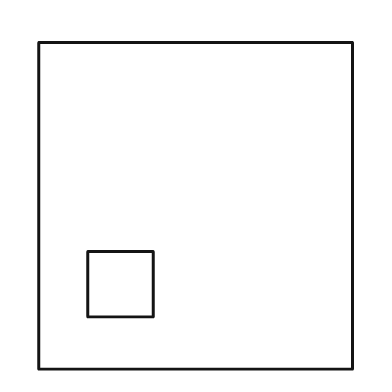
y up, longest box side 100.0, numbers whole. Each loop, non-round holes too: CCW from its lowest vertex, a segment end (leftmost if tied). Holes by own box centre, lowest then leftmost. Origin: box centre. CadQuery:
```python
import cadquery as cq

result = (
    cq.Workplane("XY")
    .moveTo(-48.0, -50.0)
    .lineTo(48.0, -50.0)
    .lineTo(48.0, 50.0)
    .lineTo(-48.0, 50.0)
    .close()
    .moveTo(-33.0, -34.0)
    .lineTo(-13.0, -34.0)
    .lineTo(-13.0, -14.0)
    .lineTo(-33.0, -14.0)
    .close()
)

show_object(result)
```